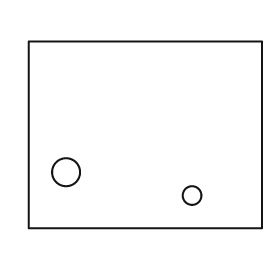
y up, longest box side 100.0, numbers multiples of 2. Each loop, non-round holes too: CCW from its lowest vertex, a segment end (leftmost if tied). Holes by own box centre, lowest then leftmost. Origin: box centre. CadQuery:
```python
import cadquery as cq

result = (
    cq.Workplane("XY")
    .moveTo(-50.0, -40.0)
    .lineTo(50.0, -40.0)
    .lineTo(50.0, 40.0)
    .lineTo(-50.0, 40.0)
    .close()
    .moveTo(20.0, -26.0)
    .circle(4.0)
    .moveTo(-34.0, -16.0)
    .circle(6.0)
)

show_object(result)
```